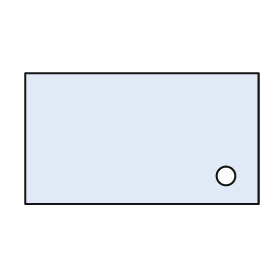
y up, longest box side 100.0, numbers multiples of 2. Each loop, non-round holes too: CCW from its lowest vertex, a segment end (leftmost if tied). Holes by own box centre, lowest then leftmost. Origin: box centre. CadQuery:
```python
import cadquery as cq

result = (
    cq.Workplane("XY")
    .moveTo(-50.0, -28.0)
    .lineTo(50.0, -28.0)
    .lineTo(50.0, 28.0)
    .lineTo(-50.0, 28.0)
    .close()
    .moveTo(36.0, -16.0)
    .circle(4.0)
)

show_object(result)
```